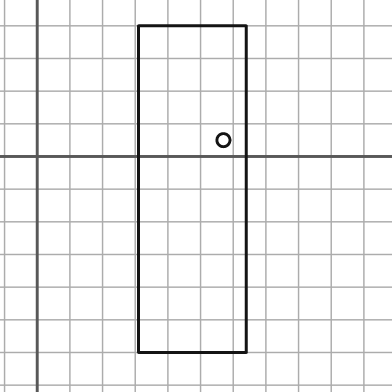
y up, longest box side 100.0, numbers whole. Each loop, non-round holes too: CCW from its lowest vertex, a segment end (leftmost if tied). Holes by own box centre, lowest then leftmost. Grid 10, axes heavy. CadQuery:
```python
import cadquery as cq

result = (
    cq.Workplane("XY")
    .moveTo(31.0, -60.0)
    .lineTo(64.0, -60.0)
    .lineTo(64.0, 40.0)
    .lineTo(31.0, 40.0)
    .close()
    .moveTo(57.0, 5.0)
    .circle(2.0)
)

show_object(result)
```